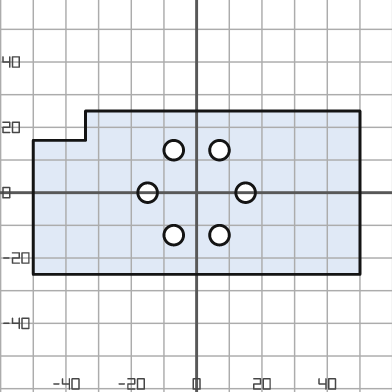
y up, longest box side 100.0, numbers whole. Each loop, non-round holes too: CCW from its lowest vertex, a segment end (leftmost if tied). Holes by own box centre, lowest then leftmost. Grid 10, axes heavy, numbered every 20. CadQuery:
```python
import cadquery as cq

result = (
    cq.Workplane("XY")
    .moveTo(-50.0, -25.0)
    .lineTo(50.0, -25.0)
    .lineTo(50.0, 25.0)
    .lineTo(-34.0, 25.0)
    .lineTo(-34.0, 16.0)
    .lineTo(-50.0, 16.0)
    .close()
    .moveTo(-7.0, -13.0)
    .circle(3.0)
    .moveTo(7.0, -13.0)
    .circle(3.0)
    .moveTo(-15.0, 0.0)
    .circle(3.0)
    .moveTo(15.0, 0.0)
    .circle(3.0)
    .moveTo(-7.0, 13.0)
    .circle(3.0)
    .moveTo(7.0, 13.0)
    .circle(3.0)
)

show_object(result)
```